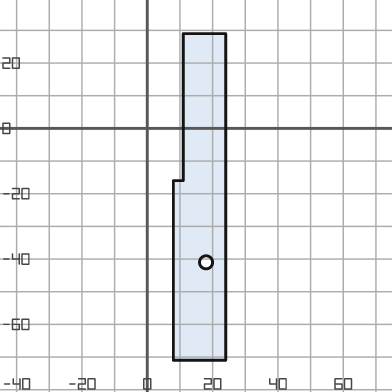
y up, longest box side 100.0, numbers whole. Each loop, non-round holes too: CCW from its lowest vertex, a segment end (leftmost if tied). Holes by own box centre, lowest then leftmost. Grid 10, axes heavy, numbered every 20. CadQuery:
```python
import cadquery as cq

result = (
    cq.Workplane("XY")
    .moveTo(8.0, -71.0)
    .lineTo(24.0, -71.0)
    .lineTo(24.0, 29.0)
    .lineTo(11.0, 29.0)
    .lineTo(11.0, -16.0)
    .lineTo(8.0, -16.0)
    .close()
    .moveTo(18.0, -41.0)
    .circle(2.0)
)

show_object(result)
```